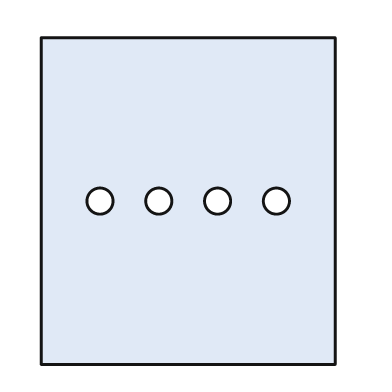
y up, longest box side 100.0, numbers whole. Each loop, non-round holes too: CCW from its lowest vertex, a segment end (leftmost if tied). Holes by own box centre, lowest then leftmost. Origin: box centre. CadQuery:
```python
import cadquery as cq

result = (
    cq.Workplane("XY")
    .moveTo(-45.0, -50.0)
    .lineTo(45.0, -50.0)
    .lineTo(45.0, 50.0)
    .lineTo(-45.0, 50.0)
    .close()
    .moveTo(-27.0, 0.0)
    .circle(4.0)
    .moveTo(-9.0, 0.0)
    .circle(4.0)
    .moveTo(9.0, 0.0)
    .circle(4.0)
    .moveTo(27.0, 0.0)
    .circle(4.0)
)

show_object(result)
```